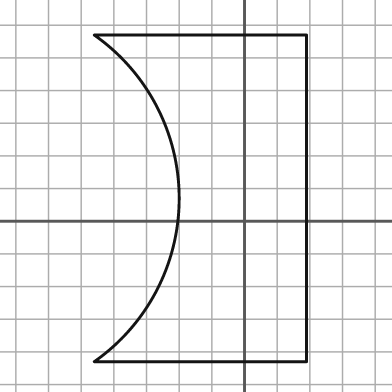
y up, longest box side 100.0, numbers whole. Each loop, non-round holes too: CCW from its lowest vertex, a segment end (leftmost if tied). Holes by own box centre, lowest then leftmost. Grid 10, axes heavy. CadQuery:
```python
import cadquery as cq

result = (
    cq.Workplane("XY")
    .moveTo(-46.0, -43.0)
    .lineTo(19.0, -43.0)
    .lineTo(19.0, 57.0)
    .lineTo(-46.0, 57.0)
    .threePointArc((-20.0, 7.0), (-46.0, -43.0))
    .close()
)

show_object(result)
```